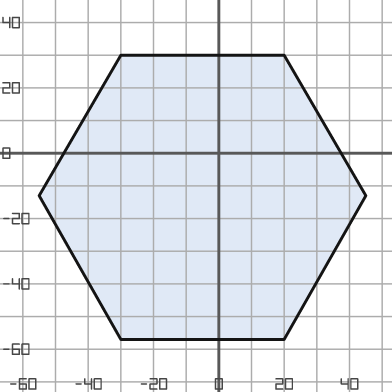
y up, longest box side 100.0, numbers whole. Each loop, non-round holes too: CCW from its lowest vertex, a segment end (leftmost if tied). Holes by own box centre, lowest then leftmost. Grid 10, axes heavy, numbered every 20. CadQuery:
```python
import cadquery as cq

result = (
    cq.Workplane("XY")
    .moveTo(-30.0, -57.0)
    .lineTo(20.0, -57.0)
    .lineTo(45.0, -13.0)
    .lineTo(20.0, 30.0)
    .lineTo(-30.0, 30.0)
    .lineTo(-55.0, -13.0)
    .close()
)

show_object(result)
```